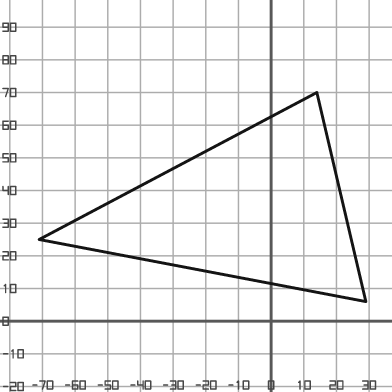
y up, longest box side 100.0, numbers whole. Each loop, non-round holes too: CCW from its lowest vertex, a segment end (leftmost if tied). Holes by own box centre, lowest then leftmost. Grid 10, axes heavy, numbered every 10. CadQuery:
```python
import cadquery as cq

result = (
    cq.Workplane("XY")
    .moveTo(29.0, 6.0)
    .lineTo(14.0, 70.0)
    .lineTo(-71.0, 25.0)
    .close()
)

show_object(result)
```